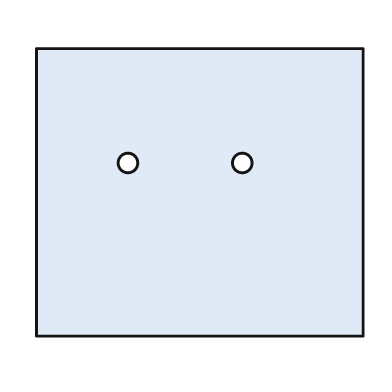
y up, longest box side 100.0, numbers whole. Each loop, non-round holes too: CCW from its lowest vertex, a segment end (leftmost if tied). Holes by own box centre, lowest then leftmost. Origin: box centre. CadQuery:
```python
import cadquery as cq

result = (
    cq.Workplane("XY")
    .moveTo(-50.0, -44.0)
    .lineTo(50.0, -44.0)
    .lineTo(50.0, 44.0)
    .lineTo(-50.0, 44.0)
    .close()
    .moveTo(-22.0, 9.0)
    .circle(3.0)
    .moveTo(13.0, 9.0)
    .circle(3.0)
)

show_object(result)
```